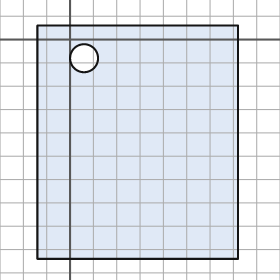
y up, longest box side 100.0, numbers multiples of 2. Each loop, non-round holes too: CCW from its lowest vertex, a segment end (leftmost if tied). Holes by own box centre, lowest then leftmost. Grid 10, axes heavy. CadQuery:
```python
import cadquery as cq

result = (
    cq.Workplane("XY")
    .moveTo(-14.0, -94.0)
    .lineTo(72.0, -94.0)
    .lineTo(72.0, 6.0)
    .lineTo(-14.0, 6.0)
    .close()
    .moveTo(6.0, -8.0)
    .circle(6.0)
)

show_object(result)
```